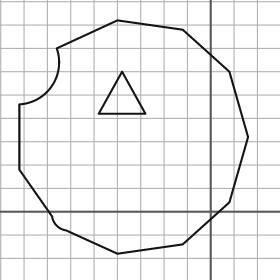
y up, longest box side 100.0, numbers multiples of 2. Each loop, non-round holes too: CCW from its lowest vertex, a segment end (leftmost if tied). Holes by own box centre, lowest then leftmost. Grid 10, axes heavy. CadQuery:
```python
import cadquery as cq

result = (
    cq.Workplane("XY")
    .moveTo(-40.0, -18.0)
    .lineTo(-12.0, -14.0)
    .lineTo(8.0, 4.0)
    .lineTo(16.0, 32.0)
    .lineTo(8.0, 60.0)
    .lineTo(-12.0, 78.0)
    .lineTo(-40.0, 82.0)
    .lineTo(-66.0, 70.0)
    .threePointArc((-68.0, 54.0), (-82.0, 46.0))
    .lineTo(-82.0, 18.0)
    .lineTo(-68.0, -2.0)
    .threePointArc((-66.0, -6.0), (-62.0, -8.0))
    .close()
    .moveTo(-48.0, 42.0)
    .lineTo(-28.0, 42.0)
    .lineTo(-38.0, 60.0)
    .close()
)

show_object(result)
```